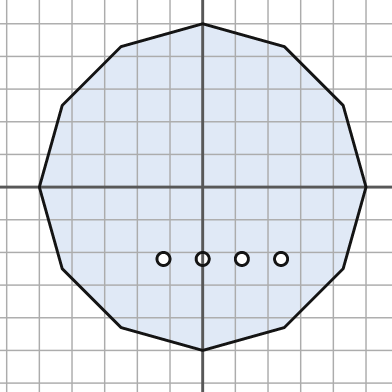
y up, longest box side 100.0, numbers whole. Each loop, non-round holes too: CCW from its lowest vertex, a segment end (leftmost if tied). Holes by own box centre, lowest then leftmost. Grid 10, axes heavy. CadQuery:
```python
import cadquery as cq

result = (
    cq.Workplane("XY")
    .moveTo(0.0, -50.0)
    .lineTo(25.0, -43.0)
    .lineTo(43.0, -25.0)
    .lineTo(50.0, 0.0)
    .lineTo(43.0, 25.0)
    .lineTo(25.0, 43.0)
    .lineTo(0.0, 50.0)
    .lineTo(-25.0, 43.0)
    .lineTo(-43.0, 25.0)
    .lineTo(-50.0, 0.0)
    .lineTo(-43.0, -25.0)
    .lineTo(-25.0, -43.0)
    .close()
    .moveTo(-12.0, -22.0)
    .circle(2.0)
    .moveTo(0.0, -22.0)
    .circle(2.0)
    .moveTo(12.0, -22.0)
    .circle(2.0)
    .moveTo(24.0, -22.0)
    .circle(2.0)
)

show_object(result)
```